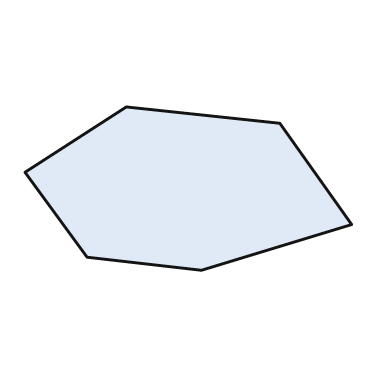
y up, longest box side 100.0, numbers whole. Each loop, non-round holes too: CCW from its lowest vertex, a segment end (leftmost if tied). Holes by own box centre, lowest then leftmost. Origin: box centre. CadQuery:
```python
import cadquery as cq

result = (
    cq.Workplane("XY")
    .moveTo(4.0, -25.0)
    .lineTo(50.0, -11.0)
    .lineTo(28.0, 20.0)
    .lineTo(-19.0, 25.0)
    .lineTo(-50.0, 5.0)
    .lineTo(-31.0, -21.0)
    .close()
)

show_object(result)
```